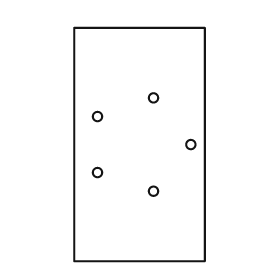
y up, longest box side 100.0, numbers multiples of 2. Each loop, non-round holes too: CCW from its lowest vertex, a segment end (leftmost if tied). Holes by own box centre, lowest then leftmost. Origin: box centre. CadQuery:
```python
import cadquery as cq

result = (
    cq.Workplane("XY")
    .moveTo(-28.0, -50.0)
    .lineTo(28.0, -50.0)
    .lineTo(28.0, 50.0)
    .lineTo(-28.0, 50.0)
    .close()
    .moveTo(6.0, -20.0)
    .circle(2.0)
    .moveTo(-18.0, -12.0)
    .circle(2.0)
    .moveTo(22.0, 0.0)
    .circle(2.0)
    .moveTo(-18.0, 12.0)
    .circle(2.0)
    .moveTo(6.0, 20.0)
    .circle(2.0)
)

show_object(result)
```